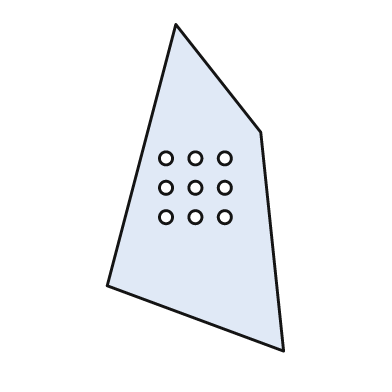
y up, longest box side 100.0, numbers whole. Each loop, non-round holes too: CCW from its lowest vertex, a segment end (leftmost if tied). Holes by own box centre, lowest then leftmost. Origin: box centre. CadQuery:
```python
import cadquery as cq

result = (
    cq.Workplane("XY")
    .moveTo(27.0, -50.0)
    .lineTo(20.0, 17.0)
    .lineTo(-6.0, 50.0)
    .lineTo(-27.0, -30.0)
    .close()
    .moveTo(-9.0, -9.0)
    .circle(2.0)
    .moveTo(0.0, -9.0)
    .circle(2.0)
    .moveTo(9.0, -9.0)
    .circle(2.0)
    .moveTo(-9.0, 0.0)
    .circle(2.0)
    .moveTo(0.0, 0.0)
    .circle(2.0)
    .moveTo(9.0, 0.0)
    .circle(2.0)
    .moveTo(-9.0, 9.0)
    .circle(2.0)
    .moveTo(0.0, 9.0)
    .circle(2.0)
    .moveTo(9.0, 9.0)
    .circle(2.0)
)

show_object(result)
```